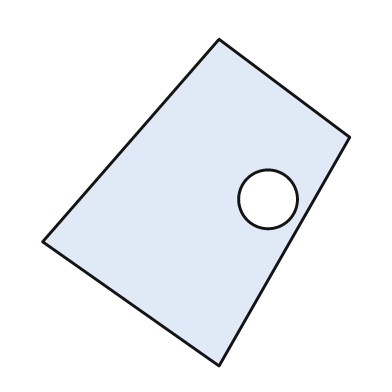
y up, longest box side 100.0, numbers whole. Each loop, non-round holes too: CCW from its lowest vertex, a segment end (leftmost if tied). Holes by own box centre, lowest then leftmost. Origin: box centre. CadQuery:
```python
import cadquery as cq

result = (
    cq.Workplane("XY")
    .moveTo(7.0, -50.0)
    .lineTo(47.0, 20.0)
    .lineTo(7.0, 50.0)
    .lineTo(-47.0, -12.0)
    .close()
    .moveTo(22.0, 1.0)
    .circle(9.0)
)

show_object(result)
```